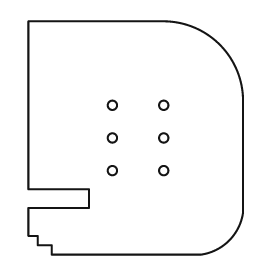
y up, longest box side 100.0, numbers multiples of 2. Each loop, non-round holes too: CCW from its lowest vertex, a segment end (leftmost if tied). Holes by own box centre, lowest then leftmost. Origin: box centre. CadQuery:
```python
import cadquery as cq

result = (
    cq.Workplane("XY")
    .moveTo(-36.0, -50.0)
    .lineTo(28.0, -50.0)
    .threePointArc((40.0, -44.0), (46.0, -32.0))
    .lineTo(46.0, 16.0)
    .threePointArc((36.0, 40.0), (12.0, 50.0))
    .lineTo(-46.0, 50.0)
    .lineTo(-46.0, -22.0)
    .lineTo(-20.0, -22.0)
    .lineTo(-20.0, -30.0)
    .lineTo(-46.0, -30.0)
    .lineTo(-46.0, -42.0)
    .lineTo(-42.0, -42.0)
    .lineTo(-42.0, -46.0)
    .lineTo(-36.0, -46.0)
    .close()
    .moveTo(-10.0, -14.0)
    .circle(2.0)
    .moveTo(12.0, -14.0)
    .circle(2.0)
    .moveTo(-10.0, 0.0)
    .circle(2.0)
    .moveTo(12.0, 0.0)
    .circle(2.0)
    .moveTo(-10.0, 14.0)
    .circle(2.0)
    .moveTo(12.0, 14.0)
    .circle(2.0)
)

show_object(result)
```